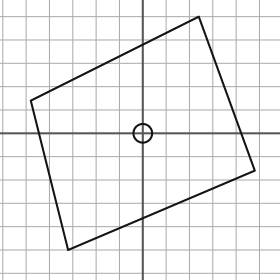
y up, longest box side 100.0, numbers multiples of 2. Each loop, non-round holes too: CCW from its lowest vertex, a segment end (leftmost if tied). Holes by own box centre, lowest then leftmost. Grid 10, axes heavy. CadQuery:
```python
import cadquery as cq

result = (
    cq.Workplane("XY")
    .moveTo(-32.0, -50.0)
    .lineTo(48.0, -16.0)
    .lineTo(24.0, 50.0)
    .lineTo(-48.0, 14.0)
    .close()
    .moveTo(0.0, 0.0)
    .circle(4.0)
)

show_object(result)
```